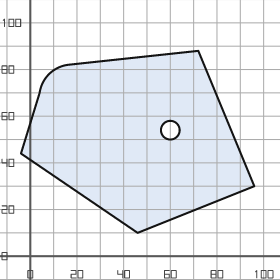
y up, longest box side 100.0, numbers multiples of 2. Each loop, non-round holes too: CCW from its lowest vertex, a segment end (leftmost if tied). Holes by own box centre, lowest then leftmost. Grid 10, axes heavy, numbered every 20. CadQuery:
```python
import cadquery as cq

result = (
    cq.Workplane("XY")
    .moveTo(46.0, 10.0)
    .lineTo(96.0, 30.0)
    .lineTo(72.0, 88.0)
    .lineTo(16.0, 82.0)
    .threePointArc((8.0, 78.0), (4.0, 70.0))
    .lineTo(-4.0, 44.0)
    .close()
    .moveTo(60.0, 54.0)
    .circle(4.0)
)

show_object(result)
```